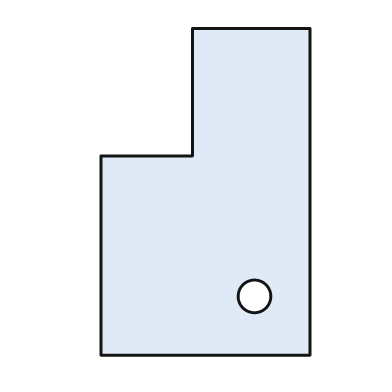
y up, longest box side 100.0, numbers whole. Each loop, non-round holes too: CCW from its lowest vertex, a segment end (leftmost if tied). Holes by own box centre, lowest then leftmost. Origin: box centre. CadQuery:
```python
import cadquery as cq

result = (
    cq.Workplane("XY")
    .moveTo(-32.0, -50.0)
    .lineTo(32.0, -50.0)
    .lineTo(32.0, 50.0)
    .lineTo(-4.0, 50.0)
    .lineTo(-4.0, 11.0)
    .lineTo(-32.0, 11.0)
    .close()
    .moveTo(15.0, -32.0)
    .circle(5.0)
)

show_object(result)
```